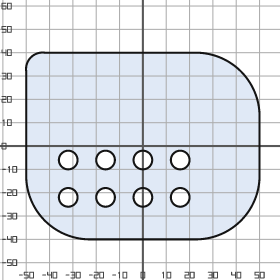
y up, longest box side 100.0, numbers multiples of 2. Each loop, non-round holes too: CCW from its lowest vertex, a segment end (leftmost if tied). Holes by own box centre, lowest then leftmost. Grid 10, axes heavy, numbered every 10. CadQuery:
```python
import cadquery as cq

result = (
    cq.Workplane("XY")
    .moveTo(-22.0, -40.0)
    .lineTo(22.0, -40.0)
    .threePointArc((42.0, -32.0), (50.0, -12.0))
    .lineTo(50.0, 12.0)
    .threePointArc((42.0, 32.0), (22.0, 40.0))
    .lineTo(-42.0, 40.0)
    .threePointArc((-48.0, 38.0), (-50.0, 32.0))
    .lineTo(-50.0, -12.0)
    .threePointArc((-42.0, -32.0), (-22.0, -40.0))
    .close()
    .moveTo(-32.0, -22.0)
    .circle(4.0)
    .moveTo(-16.0, -22.0)
    .circle(4.0)
    .moveTo(0.0, -22.0)
    .circle(4.0)
    .moveTo(16.0, -22.0)
    .circle(4.0)
    .moveTo(-32.0, -6.0)
    .circle(4.0)
    .moveTo(-16.0, -6.0)
    .circle(4.0)
    .moveTo(0.0, -6.0)
    .circle(4.0)
    .moveTo(16.0, -6.0)
    .circle(4.0)
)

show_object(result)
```